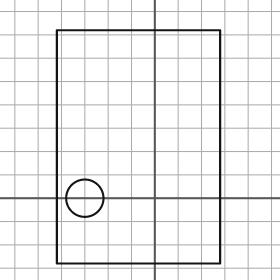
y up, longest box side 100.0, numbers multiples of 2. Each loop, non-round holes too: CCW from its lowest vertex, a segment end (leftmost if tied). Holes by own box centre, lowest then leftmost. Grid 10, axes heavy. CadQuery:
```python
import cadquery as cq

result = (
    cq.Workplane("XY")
    .moveTo(-42.0, -28.0)
    .lineTo(28.0, -28.0)
    .lineTo(28.0, 72.0)
    .lineTo(-42.0, 72.0)
    .close()
    .moveTo(-30.0, 0.0)
    .circle(8.0)
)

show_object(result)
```